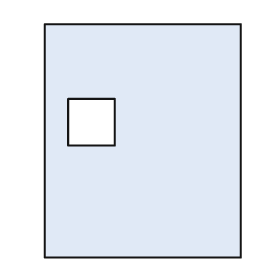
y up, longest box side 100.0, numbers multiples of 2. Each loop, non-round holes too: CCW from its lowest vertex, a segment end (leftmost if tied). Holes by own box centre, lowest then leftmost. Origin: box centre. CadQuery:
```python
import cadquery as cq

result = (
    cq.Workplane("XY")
    .moveTo(-42.0, -50.0)
    .lineTo(42.0, -50.0)
    .lineTo(42.0, 50.0)
    .lineTo(-42.0, 50.0)
    .close()
    .moveTo(-32.0, -2.0)
    .lineTo(-12.0, -2.0)
    .lineTo(-12.0, 18.0)
    .lineTo(-32.0, 18.0)
    .close()
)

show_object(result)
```